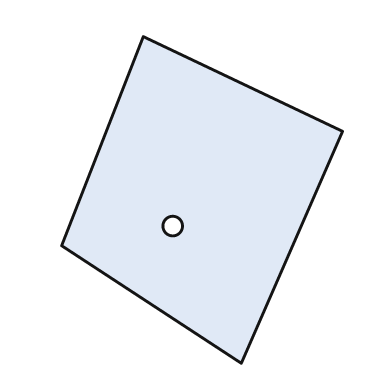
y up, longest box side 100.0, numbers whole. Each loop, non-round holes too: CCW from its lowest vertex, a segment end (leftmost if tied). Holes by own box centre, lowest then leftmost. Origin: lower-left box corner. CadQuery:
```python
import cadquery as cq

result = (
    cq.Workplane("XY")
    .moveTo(55.0, 0.0)
    .lineTo(86.0, 71.0)
    .lineTo(25.0, 100.0)
    .lineTo(0.0, 36.0)
    .close()
    .moveTo(34.0, 42.0)
    .circle(3.0)
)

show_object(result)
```